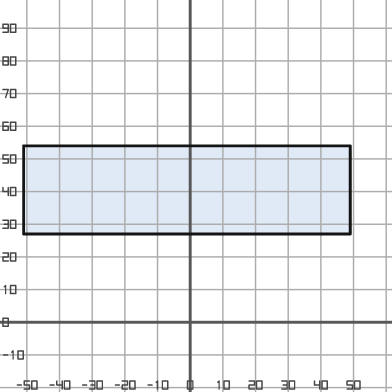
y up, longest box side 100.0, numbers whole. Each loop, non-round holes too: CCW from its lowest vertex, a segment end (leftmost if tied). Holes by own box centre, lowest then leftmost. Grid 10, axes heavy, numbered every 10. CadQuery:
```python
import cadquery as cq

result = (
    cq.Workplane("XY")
    .moveTo(-51.0, 27.0)
    .lineTo(49.0, 27.0)
    .lineTo(49.0, 54.0)
    .lineTo(-51.0, 54.0)
    .close()
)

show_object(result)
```